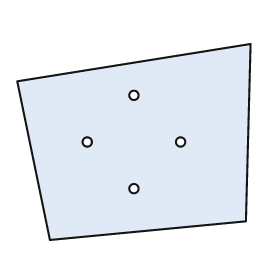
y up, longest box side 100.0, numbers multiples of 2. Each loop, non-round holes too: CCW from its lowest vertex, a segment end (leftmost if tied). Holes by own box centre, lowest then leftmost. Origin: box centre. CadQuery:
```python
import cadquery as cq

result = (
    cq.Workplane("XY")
    .moveTo(-36.0, -42.0)
    .lineTo(48.0, -34.0)
    .lineTo(50.0, 42.0)
    .lineTo(-50.0, 26.0)
    .close()
    .moveTo(0.0, -20.0)
    .circle(2.0)
    .moveTo(-20.0, 0.0)
    .circle(2.0)
    .moveTo(20.0, 0.0)
    .circle(2.0)
    .moveTo(0.0, 20.0)
    .circle(2.0)
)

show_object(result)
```